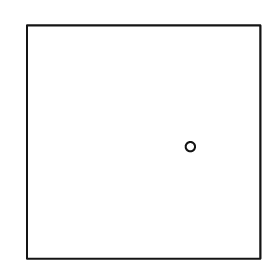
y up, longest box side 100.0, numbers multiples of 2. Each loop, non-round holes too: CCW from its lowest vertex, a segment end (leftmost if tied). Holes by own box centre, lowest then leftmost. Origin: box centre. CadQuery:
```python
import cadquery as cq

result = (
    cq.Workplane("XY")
    .moveTo(-50.0, -50.0)
    .lineTo(50.0, -50.0)
    .lineTo(50.0, 50.0)
    .lineTo(-50.0, 50.0)
    .close()
    .moveTo(20.0, -2.0)
    .circle(2.0)
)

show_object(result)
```